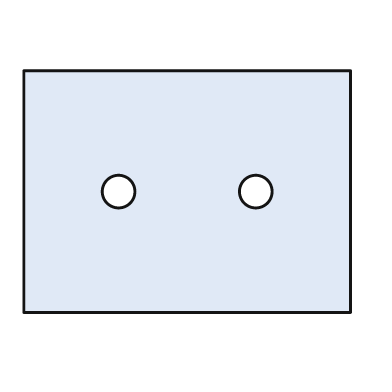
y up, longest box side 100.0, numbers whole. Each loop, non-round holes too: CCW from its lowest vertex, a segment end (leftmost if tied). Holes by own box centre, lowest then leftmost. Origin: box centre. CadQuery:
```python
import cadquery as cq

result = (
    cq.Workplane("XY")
    .moveTo(-50.0, -37.0)
    .lineTo(50.0, -37.0)
    .lineTo(50.0, 37.0)
    .lineTo(-50.0, 37.0)
    .close()
    .moveTo(-21.0, 0.0)
    .circle(5.0)
    .moveTo(21.0, 0.0)
    .circle(5.0)
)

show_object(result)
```